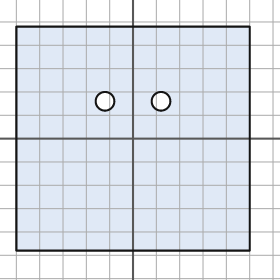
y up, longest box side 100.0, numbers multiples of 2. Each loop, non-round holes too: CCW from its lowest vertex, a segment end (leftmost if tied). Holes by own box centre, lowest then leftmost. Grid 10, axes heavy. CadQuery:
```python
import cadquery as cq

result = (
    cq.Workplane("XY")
    .moveTo(-50.0, -48.0)
    .lineTo(50.0, -48.0)
    .lineTo(50.0, 48.0)
    .lineTo(-50.0, 48.0)
    .close()
    .moveTo(-12.0, 16.0)
    .circle(4.0)
    .moveTo(12.0, 16.0)
    .circle(4.0)
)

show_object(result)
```